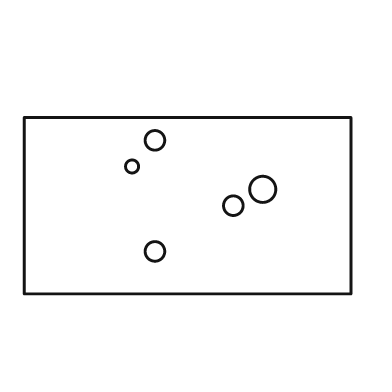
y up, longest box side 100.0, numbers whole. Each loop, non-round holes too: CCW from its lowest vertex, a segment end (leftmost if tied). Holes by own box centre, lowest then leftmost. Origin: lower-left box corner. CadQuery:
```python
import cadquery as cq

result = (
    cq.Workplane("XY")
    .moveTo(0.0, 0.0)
    .lineTo(100.0, 0.0)
    .lineTo(100.0, 54.0)
    .lineTo(0.0, 54.0)
    .close()
    .moveTo(40.0, 13.0)
    .circle(3.0)
    .moveTo(64.0, 27.0)
    .circle(3.0)
    .moveTo(73.0, 32.0)
    .circle(4.0)
    .moveTo(33.0, 39.0)
    .circle(2.0)
    .moveTo(40.0, 47.0)
    .circle(3.0)
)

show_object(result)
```